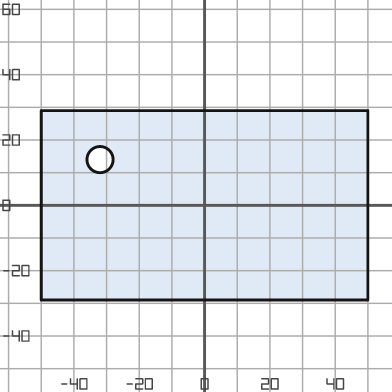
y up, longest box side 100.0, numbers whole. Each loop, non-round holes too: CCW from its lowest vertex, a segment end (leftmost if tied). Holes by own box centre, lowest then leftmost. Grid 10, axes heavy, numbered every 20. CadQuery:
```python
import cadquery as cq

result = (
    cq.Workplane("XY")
    .moveTo(-50.0, -29.0)
    .lineTo(50.0, -29.0)
    .lineTo(50.0, 29.0)
    .lineTo(-50.0, 29.0)
    .close()
    .moveTo(-32.0, 14.0)
    .circle(4.0)
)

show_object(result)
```